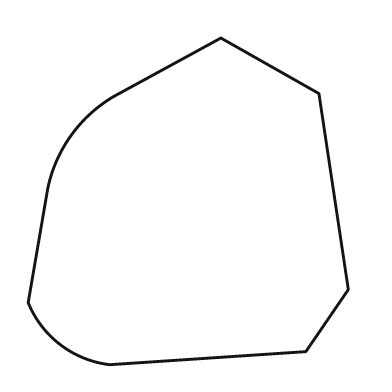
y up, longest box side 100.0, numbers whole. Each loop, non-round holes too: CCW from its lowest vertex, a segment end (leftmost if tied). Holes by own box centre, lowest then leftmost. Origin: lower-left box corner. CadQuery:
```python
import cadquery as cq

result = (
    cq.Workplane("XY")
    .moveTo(25.0, 0.0)
    .lineTo(85.0, 4.0)
    .lineTo(98.0, 23.0)
    .lineTo(89.0, 83.0)
    .lineTo(59.0, 100.0)
    .lineTo(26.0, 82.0)
    .threePointArc((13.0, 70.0), (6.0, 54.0))
    .lineTo(0.0, 19.0)
    .threePointArc((10.0, 6.0), (25.0, 0.0))
    .close()
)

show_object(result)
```